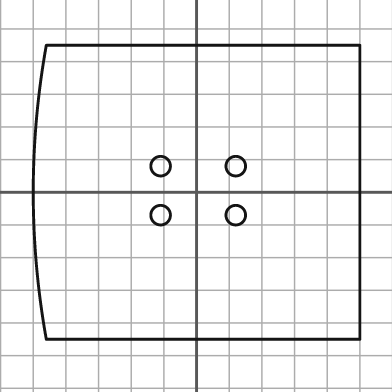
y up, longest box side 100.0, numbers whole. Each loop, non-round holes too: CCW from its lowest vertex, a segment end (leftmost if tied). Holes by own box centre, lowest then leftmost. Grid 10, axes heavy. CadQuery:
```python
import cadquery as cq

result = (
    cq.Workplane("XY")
    .moveTo(-46.0, -45.0)
    .lineTo(50.0, -45.0)
    .lineTo(50.0, 45.0)
    .lineTo(-46.0, 45.0)
    .threePointArc((-50.0, 0.0), (-46.0, -45.0))
    .close()
    .moveTo(-11.0, -7.0)
    .circle(3.0)
    .moveTo(12.0, -7.0)
    .circle(3.0)
    .moveTo(-11.0, 8.0)
    .circle(3.0)
    .moveTo(12.0, 8.0)
    .circle(3.0)
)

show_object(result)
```